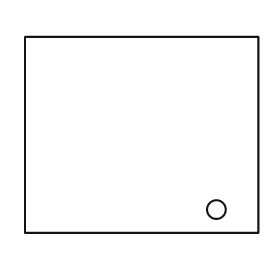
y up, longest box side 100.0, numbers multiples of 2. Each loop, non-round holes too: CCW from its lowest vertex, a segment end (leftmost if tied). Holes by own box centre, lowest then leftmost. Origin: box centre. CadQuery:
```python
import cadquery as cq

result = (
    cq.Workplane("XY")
    .moveTo(-50.0, -42.0)
    .lineTo(50.0, -42.0)
    .lineTo(50.0, 42.0)
    .lineTo(-50.0, 42.0)
    .close()
    .moveTo(32.0, -32.0)
    .circle(4.0)
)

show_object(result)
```